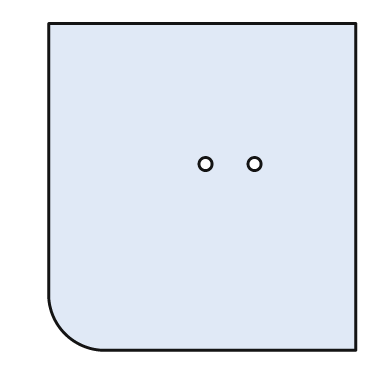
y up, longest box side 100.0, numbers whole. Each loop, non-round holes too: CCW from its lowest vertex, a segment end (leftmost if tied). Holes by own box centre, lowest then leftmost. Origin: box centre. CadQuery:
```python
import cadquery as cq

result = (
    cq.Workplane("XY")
    .moveTo(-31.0, -50.0)
    .lineTo(47.0, -50.0)
    .lineTo(47.0, 50.0)
    .lineTo(-47.0, 50.0)
    .lineTo(-47.0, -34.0)
    .threePointArc((-42.0, -45.0), (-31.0, -50.0))
    .close()
    .moveTo(1.0, 7.0)
    .circle(2.0)
    .moveTo(16.0, 7.0)
    .circle(2.0)
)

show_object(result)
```